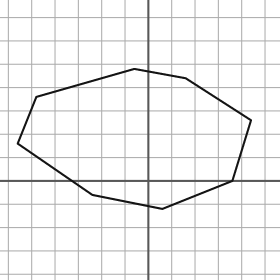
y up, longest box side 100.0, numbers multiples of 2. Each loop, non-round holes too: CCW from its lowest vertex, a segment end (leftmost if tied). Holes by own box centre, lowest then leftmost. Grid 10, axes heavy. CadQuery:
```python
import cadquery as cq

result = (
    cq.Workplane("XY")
    .moveTo(6.0, -12.0)
    .lineTo(36.0, 0.0)
    .lineTo(44.0, 26.0)
    .lineTo(16.0, 44.0)
    .lineTo(-6.0, 48.0)
    .lineTo(-48.0, 36.0)
    .lineTo(-56.0, 16.0)
    .lineTo(-24.0, -6.0)
    .close()
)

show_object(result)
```